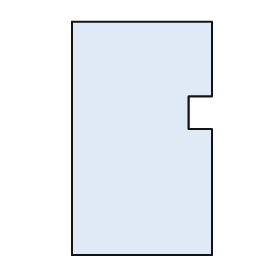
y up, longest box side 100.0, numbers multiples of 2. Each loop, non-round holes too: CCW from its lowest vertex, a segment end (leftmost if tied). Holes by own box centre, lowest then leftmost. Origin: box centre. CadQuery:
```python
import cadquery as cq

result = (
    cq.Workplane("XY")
    .moveTo(-30.0, -50.0)
    .lineTo(30.0, -50.0)
    .lineTo(30.0, 4.0)
    .lineTo(20.0, 4.0)
    .lineTo(20.0, 18.0)
    .lineTo(30.0, 18.0)
    .lineTo(30.0, 50.0)
    .lineTo(-30.0, 50.0)
    .close()
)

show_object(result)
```